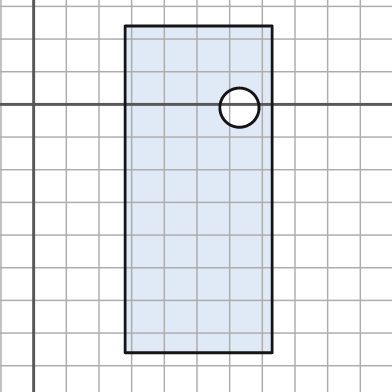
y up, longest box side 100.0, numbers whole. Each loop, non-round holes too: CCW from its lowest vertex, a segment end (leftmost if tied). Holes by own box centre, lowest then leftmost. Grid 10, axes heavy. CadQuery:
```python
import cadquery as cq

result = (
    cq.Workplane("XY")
    .moveTo(28.0, -76.0)
    .lineTo(73.0, -76.0)
    .lineTo(73.0, 24.0)
    .lineTo(28.0, 24.0)
    .close()
    .moveTo(63.0, -1.0)
    .circle(6.0)
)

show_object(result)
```